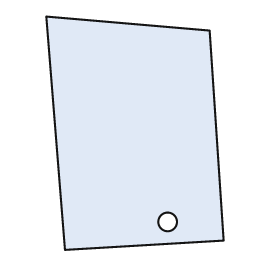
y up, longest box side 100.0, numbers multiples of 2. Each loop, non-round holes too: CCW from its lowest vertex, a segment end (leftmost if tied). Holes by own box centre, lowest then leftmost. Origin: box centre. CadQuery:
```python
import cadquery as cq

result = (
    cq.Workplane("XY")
    .moveTo(-30.0, -50.0)
    .lineTo(38.0, -46.0)
    .lineTo(32.0, 44.0)
    .lineTo(-38.0, 50.0)
    .close()
    .moveTo(14.0, -38.0)
    .circle(4.0)
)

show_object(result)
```